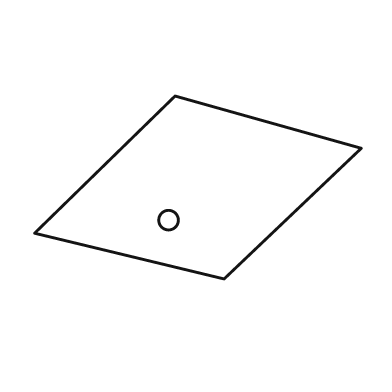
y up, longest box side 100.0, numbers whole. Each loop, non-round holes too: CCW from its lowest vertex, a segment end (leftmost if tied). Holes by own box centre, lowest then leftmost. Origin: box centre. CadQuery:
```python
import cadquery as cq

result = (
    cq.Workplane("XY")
    .moveTo(8.0, -28.0)
    .lineTo(50.0, 12.0)
    .lineTo(-7.0, 28.0)
    .lineTo(-50.0, -14.0)
    .close()
    .moveTo(-9.0, -10.0)
    .circle(3.0)
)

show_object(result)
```